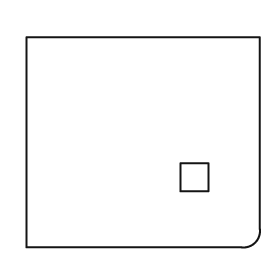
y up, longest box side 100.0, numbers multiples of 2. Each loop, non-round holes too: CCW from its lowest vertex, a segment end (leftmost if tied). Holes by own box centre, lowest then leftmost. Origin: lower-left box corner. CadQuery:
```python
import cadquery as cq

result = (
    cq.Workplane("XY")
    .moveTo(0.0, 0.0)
    .lineTo(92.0, 0.0)
    .threePointArc((98.0, 2.0), (100.0, 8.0))
    .lineTo(100.0, 90.0)
    .lineTo(0.0, 90.0)
    .close()
    .moveTo(66.0, 24.0)
    .lineTo(78.0, 24.0)
    .lineTo(78.0, 36.0)
    .lineTo(66.0, 36.0)
    .close()
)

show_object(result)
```